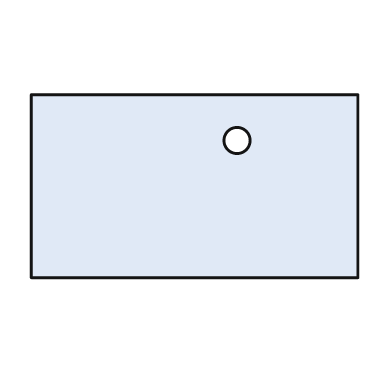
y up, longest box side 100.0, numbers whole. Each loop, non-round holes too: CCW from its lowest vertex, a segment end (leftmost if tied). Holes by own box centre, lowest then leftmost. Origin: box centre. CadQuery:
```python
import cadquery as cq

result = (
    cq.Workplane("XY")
    .moveTo(-50.0, -28.0)
    .lineTo(50.0, -28.0)
    .lineTo(50.0, 28.0)
    .lineTo(-50.0, 28.0)
    .close()
    .moveTo(13.0, 14.0)
    .circle(4.0)
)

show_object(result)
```